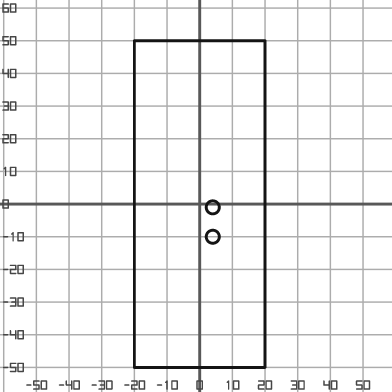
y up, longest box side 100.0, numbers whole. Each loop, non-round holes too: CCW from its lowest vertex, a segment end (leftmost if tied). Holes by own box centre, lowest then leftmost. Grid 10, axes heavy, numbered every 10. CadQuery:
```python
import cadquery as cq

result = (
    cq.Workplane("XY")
    .moveTo(-20.0, -50.0)
    .lineTo(20.0, -50.0)
    .lineTo(20.0, 50.0)
    .lineTo(-20.0, 50.0)
    .close()
    .moveTo(4.0, -10.0)
    .circle(2.0)
    .moveTo(4.0, -1.0)
    .circle(2.0)
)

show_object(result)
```